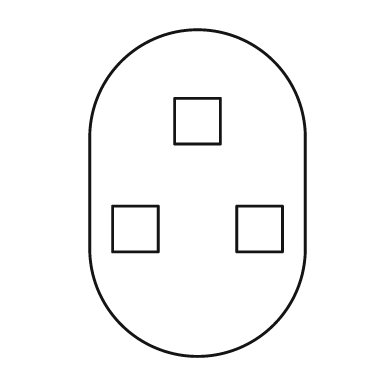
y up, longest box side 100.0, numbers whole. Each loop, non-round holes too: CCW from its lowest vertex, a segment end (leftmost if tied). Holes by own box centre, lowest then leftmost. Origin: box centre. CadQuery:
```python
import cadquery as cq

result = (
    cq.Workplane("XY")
    .moveTo(-33.0, -17.0)
    .threePointArc((0.0, -50.0), (33.0, -17.0))
    .lineTo(33.0, 17.0)
    .threePointArc((0.0, 50.0), (-33.0, 17.0))
    .close()
    .moveTo(-26.0, -18.0)
    .lineTo(-12.0, -18.0)
    .lineTo(-12.0, -4.0)
    .lineTo(-26.0, -4.0)
    .close()
    .moveTo(12.0, -18.0)
    .lineTo(26.0, -18.0)
    .lineTo(26.0, -4.0)
    .lineTo(12.0, -4.0)
    .close()
    .moveTo(-7.0, 15.0)
    .lineTo(7.0, 15.0)
    .lineTo(7.0, 29.0)
    .lineTo(-7.0, 29.0)
    .close()
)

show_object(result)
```